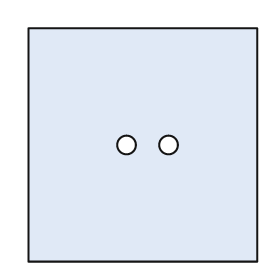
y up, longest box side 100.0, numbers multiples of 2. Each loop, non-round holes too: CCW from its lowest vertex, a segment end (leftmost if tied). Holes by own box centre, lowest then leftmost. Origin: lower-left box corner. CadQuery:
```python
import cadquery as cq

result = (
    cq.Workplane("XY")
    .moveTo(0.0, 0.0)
    .lineTo(98.0, 0.0)
    .lineTo(98.0, 100.0)
    .lineTo(0.0, 100.0)
    .close()
    .moveTo(42.0, 50.0)
    .circle(4.0)
    .moveTo(60.0, 50.0)
    .circle(4.0)
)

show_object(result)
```